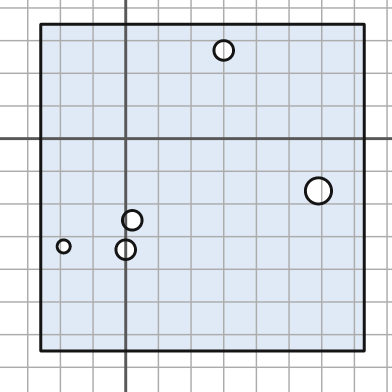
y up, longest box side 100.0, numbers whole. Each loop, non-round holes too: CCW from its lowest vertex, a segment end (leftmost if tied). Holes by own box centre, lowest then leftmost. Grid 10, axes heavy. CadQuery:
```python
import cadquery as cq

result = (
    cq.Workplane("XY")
    .moveTo(-26.0, -65.0)
    .lineTo(73.0, -65.0)
    .lineTo(73.0, 35.0)
    .lineTo(-26.0, 35.0)
    .close()
    .moveTo(0.0, -34.0)
    .circle(3.0)
    .moveTo(-19.0, -33.0)
    .circle(2.0)
    .moveTo(2.0, -25.0)
    .circle(3.0)
    .moveTo(59.0, -16.0)
    .circle(4.0)
    .moveTo(30.0, 27.0)
    .circle(3.0)
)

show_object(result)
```